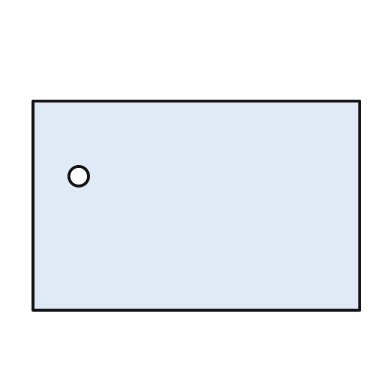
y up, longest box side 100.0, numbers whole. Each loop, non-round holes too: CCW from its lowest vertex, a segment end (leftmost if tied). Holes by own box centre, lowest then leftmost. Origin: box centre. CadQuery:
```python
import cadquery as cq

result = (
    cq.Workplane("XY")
    .moveTo(-50.0, -32.0)
    .lineTo(50.0, -32.0)
    .lineTo(50.0, 32.0)
    .lineTo(-50.0, 32.0)
    .close()
    .moveTo(-36.0, 9.0)
    .circle(3.0)
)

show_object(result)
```